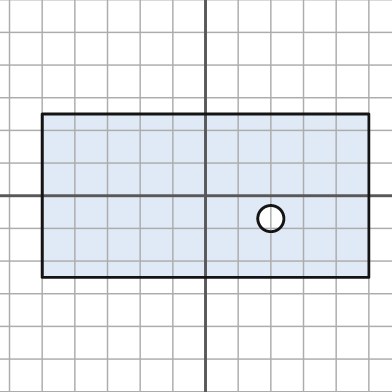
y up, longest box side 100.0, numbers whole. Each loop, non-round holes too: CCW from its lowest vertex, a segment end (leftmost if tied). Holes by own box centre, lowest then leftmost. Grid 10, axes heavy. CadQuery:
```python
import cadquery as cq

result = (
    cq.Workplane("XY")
    .moveTo(-50.0, -25.0)
    .lineTo(50.0, -25.0)
    .lineTo(50.0, 25.0)
    .lineTo(-50.0, 25.0)
    .close()
    .moveTo(20.0, -7.0)
    .circle(4.0)
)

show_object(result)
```